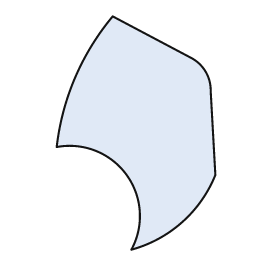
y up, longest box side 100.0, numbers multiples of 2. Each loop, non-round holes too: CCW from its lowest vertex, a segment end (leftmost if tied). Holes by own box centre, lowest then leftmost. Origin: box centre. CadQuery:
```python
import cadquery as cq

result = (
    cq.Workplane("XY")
    .moveTo(-2.0, -50.0)
    .threePointArc((20.0, -38.0), (34.0, -18.0))
    .lineTo(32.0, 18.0)
    .threePointArc((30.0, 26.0), (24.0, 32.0))
    .lineTo(-10.0, 50.0)
    .threePointArc((-26.0, 24.0), (-34.0, -6.0))
    .threePointArc((-4.0, -18.0), (-2.0, -50.0))
    .close()
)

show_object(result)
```